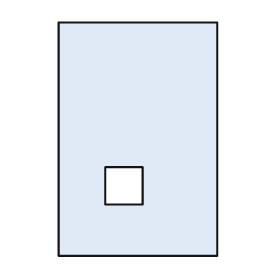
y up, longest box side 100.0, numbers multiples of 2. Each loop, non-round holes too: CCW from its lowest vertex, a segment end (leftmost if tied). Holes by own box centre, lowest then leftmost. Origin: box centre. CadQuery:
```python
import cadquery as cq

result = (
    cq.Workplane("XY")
    .moveTo(-34.0, -50.0)
    .lineTo(34.0, -50.0)
    .lineTo(34.0, 50.0)
    .lineTo(-34.0, 50.0)
    .close()
    .moveTo(-14.0, -28.0)
    .lineTo(2.0, -28.0)
    .lineTo(2.0, -12.0)
    .lineTo(-14.0, -12.0)
    .close()
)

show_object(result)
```